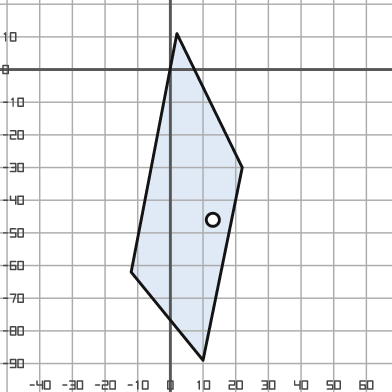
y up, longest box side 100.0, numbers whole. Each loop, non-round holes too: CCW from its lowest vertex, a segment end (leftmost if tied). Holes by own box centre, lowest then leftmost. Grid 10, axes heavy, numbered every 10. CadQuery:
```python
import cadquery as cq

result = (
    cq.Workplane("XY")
    .moveTo(10.0, -89.0)
    .lineTo(22.0, -30.0)
    .lineTo(2.0, 11.0)
    .lineTo(-12.0, -62.0)
    .close()
    .moveTo(13.0, -46.0)
    .circle(2.0)
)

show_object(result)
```